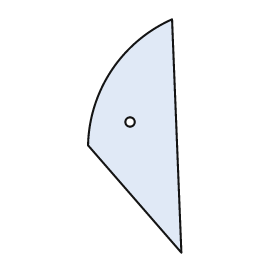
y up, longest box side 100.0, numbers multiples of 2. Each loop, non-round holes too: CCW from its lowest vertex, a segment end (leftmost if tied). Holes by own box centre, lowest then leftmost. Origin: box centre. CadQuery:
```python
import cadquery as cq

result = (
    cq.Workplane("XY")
    .moveTo(20.0, -50.0)
    .lineTo(16.0, 50.0)
    .threePointArc((-10.0, 28.0), (-20.0, -4.0))
    .close()
    .moveTo(-2.0, 6.0)
    .circle(2.0)
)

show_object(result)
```